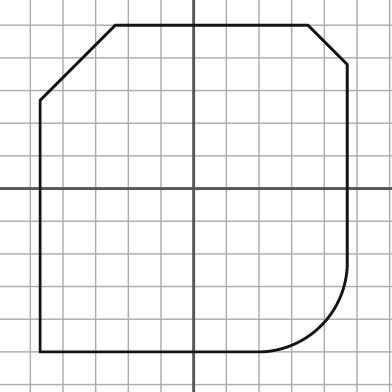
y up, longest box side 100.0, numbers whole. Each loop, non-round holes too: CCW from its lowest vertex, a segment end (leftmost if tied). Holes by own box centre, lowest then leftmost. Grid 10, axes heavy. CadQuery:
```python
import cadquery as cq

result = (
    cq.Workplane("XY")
    .moveTo(-47.0, -50.0)
    .lineTo(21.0, -50.0)
    .threePointArc((39.0, -42.0), (47.0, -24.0))
    .lineTo(47.0, 38.0)
    .lineTo(35.0, 50.0)
    .lineTo(-24.0, 50.0)
    .lineTo(-47.0, 27.0)
    .close()
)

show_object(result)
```